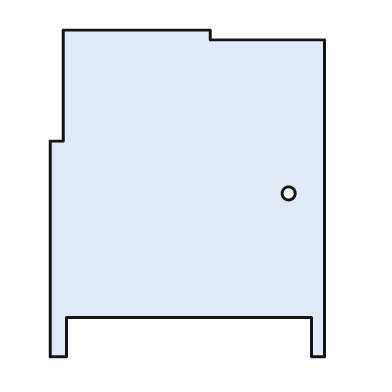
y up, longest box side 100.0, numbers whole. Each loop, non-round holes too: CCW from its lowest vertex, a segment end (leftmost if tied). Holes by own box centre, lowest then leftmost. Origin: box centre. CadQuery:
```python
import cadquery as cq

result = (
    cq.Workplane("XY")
    .moveTo(-42.0, -50.0)
    .lineTo(-37.0, -50.0)
    .lineTo(-37.0, -38.0)
    .lineTo(38.0, -38.0)
    .lineTo(38.0, -50.0)
    .lineTo(42.0, -50.0)
    .lineTo(42.0, 47.0)
    .lineTo(7.0, 47.0)
    .lineTo(7.0, 50.0)
    .lineTo(-38.0, 50.0)
    .lineTo(-38.0, 16.0)
    .lineTo(-42.0, 16.0)
    .close()
    .moveTo(31.0, 0.0)
    .circle(2.0)
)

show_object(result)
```